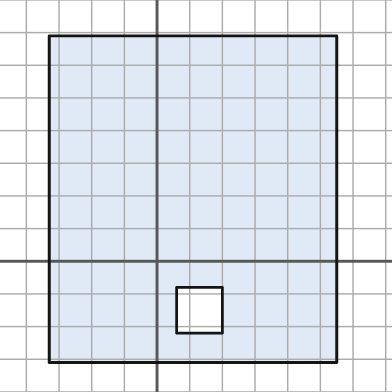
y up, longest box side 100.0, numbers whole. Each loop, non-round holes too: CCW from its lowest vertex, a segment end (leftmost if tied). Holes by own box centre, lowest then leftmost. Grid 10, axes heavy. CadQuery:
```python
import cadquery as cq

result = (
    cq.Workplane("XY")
    .moveTo(-33.0, -31.0)
    .lineTo(55.0, -31.0)
    .lineTo(55.0, 69.0)
    .lineTo(-33.0, 69.0)
    .close()
    .moveTo(6.0, -22.0)
    .lineTo(20.0, -22.0)
    .lineTo(20.0, -8.0)
    .lineTo(6.0, -8.0)
    .close()
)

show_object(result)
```